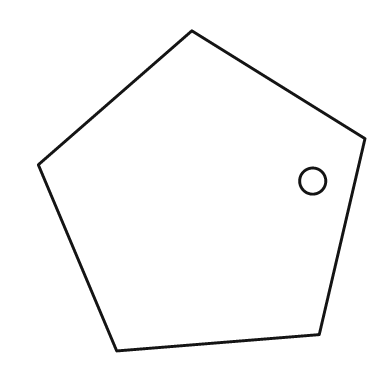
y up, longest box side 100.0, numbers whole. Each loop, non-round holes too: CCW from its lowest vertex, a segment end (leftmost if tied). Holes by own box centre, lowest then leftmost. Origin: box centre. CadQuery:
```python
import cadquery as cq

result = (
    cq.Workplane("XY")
    .moveTo(-26.0, -49.0)
    .lineTo(36.0, -44.0)
    .lineTo(50.0, 16.0)
    .lineTo(-3.0, 49.0)
    .lineTo(-50.0, 8.0)
    .close()
    .moveTo(34.0, 3.0)
    .circle(4.0)
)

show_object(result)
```